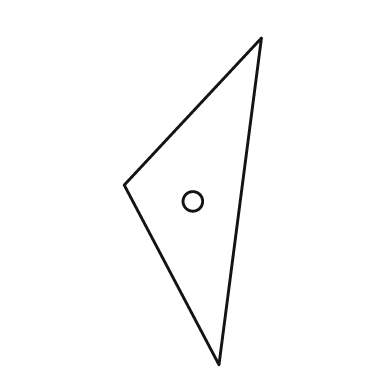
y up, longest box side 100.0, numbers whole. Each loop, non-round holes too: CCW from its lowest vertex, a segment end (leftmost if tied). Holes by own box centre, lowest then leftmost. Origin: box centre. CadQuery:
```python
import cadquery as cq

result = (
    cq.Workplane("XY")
    .moveTo(8.0, -50.0)
    .lineTo(21.0, 50.0)
    .lineTo(-21.0, 5.0)
    .close()
    .moveTo(0.0, 0.0)
    .circle(3.0)
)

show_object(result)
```